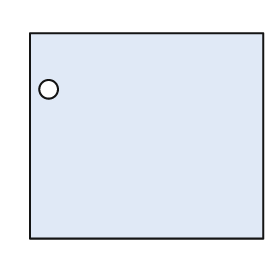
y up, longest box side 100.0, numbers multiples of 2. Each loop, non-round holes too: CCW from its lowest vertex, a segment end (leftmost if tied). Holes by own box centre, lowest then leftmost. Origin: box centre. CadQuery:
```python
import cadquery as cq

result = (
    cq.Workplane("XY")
    .moveTo(-50.0, -44.0)
    .lineTo(50.0, -44.0)
    .lineTo(50.0, 44.0)
    .lineTo(-50.0, 44.0)
    .close()
    .moveTo(-42.0, 20.0)
    .circle(4.0)
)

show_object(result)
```